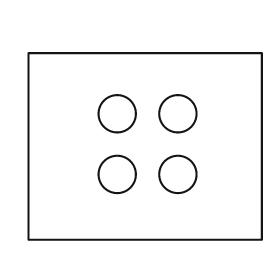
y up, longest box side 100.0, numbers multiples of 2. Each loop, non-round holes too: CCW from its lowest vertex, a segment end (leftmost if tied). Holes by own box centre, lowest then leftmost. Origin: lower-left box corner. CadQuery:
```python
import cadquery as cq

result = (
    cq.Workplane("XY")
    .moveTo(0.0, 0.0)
    .lineTo(100.0, 0.0)
    .lineTo(100.0, 80.0)
    .lineTo(0.0, 80.0)
    .close()
    .moveTo(38.0, 28.0)
    .circle(8.0)
    .moveTo(64.0, 28.0)
    .circle(8.0)
    .moveTo(38.0, 54.0)
    .circle(8.0)
    .moveTo(64.0, 54.0)
    .circle(8.0)
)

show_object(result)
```